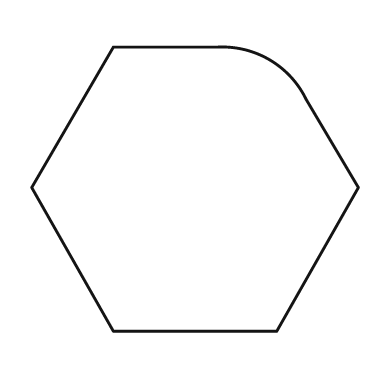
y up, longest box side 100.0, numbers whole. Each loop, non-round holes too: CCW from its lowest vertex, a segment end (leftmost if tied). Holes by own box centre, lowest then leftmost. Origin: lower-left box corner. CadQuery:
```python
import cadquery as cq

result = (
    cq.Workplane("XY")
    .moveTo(25.0, 0.0)
    .lineTo(75.0, 0.0)
    .lineTo(100.0, 44.0)
    .lineTo(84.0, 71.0)
    .threePointArc((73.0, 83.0), (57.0, 87.0))
    .lineTo(25.0, 87.0)
    .lineTo(0.0, 44.0)
    .close()
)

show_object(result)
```